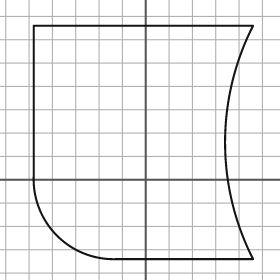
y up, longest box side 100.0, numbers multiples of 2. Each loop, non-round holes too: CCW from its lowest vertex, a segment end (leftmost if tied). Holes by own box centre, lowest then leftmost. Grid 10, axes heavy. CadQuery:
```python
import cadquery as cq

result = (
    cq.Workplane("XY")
    .moveTo(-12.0, -34.0)
    .lineTo(46.0, -34.0)
    .threePointArc((34.0, 16.0), (46.0, 66.0))
    .lineTo(-48.0, 66.0)
    .lineTo(-48.0, 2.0)
    .threePointArc((-38.0, -24.0), (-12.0, -34.0))
    .close()
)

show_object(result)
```